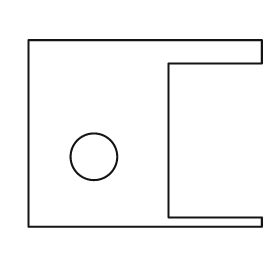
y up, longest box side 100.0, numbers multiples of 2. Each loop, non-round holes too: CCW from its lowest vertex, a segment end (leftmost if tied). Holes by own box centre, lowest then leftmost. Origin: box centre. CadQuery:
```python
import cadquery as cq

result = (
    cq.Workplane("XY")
    .moveTo(-50.0, -40.0)
    .lineTo(50.0, -40.0)
    .lineTo(50.0, -36.0)
    .lineTo(10.0, -36.0)
    .lineTo(10.0, 30.0)
    .lineTo(50.0, 30.0)
    .lineTo(50.0, 40.0)
    .lineTo(-50.0, 40.0)
    .close()
    .moveTo(-22.0, -10.0)
    .circle(10.0)
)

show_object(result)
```